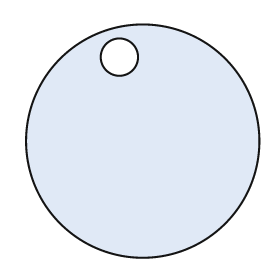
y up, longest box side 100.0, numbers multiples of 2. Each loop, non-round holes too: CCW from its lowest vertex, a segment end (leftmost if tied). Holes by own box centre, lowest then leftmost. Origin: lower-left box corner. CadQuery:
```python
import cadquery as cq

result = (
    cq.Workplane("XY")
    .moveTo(50.0, 50.0)
    .circle(50.0)
    .moveTo(40.0, 86.0)
    .circle(8.0)
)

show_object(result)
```